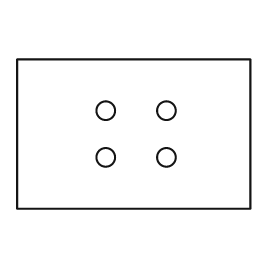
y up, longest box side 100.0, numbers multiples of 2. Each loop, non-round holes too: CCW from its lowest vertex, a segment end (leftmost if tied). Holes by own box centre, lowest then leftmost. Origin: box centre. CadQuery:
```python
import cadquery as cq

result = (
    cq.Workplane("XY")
    .moveTo(-50.0, -32.0)
    .lineTo(50.0, -32.0)
    .lineTo(50.0, 32.0)
    .lineTo(-50.0, 32.0)
    .close()
    .moveTo(-12.0, -10.0)
    .circle(4.0)
    .moveTo(14.0, -10.0)
    .circle(4.0)
    .moveTo(-12.0, 10.0)
    .circle(4.0)
    .moveTo(14.0, 10.0)
    .circle(4.0)
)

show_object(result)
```